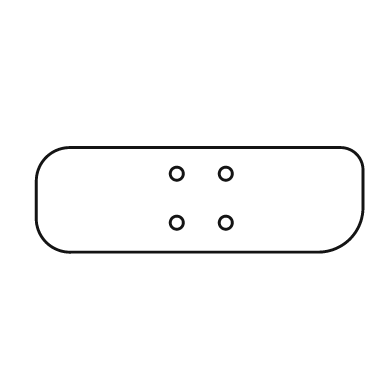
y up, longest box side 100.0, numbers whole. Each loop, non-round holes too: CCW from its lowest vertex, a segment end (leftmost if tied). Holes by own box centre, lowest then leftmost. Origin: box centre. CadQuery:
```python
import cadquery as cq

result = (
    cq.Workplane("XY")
    .moveTo(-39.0, -16.0)
    .lineTo(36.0, -16.0)
    .threePointArc((46.0, -12.0), (50.0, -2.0))
    .lineTo(50.0, 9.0)
    .threePointArc((48.0, 14.0), (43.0, 16.0))
    .lineTo(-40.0, 16.0)
    .threePointArc((-47.0, 13.0), (-50.0, 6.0))
    .lineTo(-50.0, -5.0)
    .threePointArc((-47.0, -13.0), (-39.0, -16.0))
    .close()
    .moveTo(-7.0, -7.0)
    .circle(2.0)
    .moveTo(8.0, -7.0)
    .circle(2.0)
    .moveTo(-7.0, 8.0)
    .circle(2.0)
    .moveTo(8.0, 8.0)
    .circle(2.0)
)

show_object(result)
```